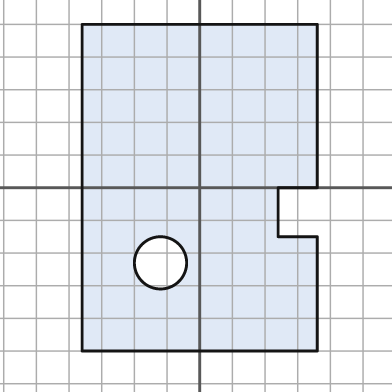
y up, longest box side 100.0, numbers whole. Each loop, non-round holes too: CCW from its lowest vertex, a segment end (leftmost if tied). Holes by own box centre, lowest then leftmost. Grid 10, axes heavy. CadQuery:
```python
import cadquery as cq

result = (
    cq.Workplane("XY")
    .moveTo(-36.0, -50.0)
    .lineTo(36.0, -50.0)
    .lineTo(36.0, -15.0)
    .lineTo(24.0, -15.0)
    .lineTo(24.0, 0.0)
    .lineTo(36.0, 0.0)
    .lineTo(36.0, 50.0)
    .lineTo(-36.0, 50.0)
    .close()
    .moveTo(-12.0, -23.0)
    .circle(8.0)
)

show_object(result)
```